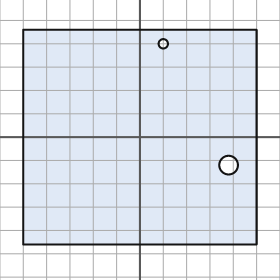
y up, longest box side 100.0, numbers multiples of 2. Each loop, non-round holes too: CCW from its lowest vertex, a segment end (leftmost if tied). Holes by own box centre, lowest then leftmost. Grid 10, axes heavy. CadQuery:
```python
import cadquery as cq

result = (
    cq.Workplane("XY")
    .moveTo(-50.0, -46.0)
    .lineTo(50.0, -46.0)
    .lineTo(50.0, 46.0)
    .lineTo(-50.0, 46.0)
    .close()
    .moveTo(38.0, -12.0)
    .circle(4.0)
    .moveTo(10.0, 40.0)
    .circle(2.0)
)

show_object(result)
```